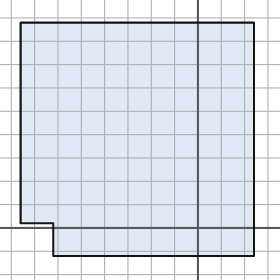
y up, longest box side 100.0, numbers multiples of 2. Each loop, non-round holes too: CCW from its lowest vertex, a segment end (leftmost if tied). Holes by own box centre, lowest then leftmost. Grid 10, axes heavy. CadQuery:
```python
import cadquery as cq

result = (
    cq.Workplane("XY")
    .moveTo(-62.0, -12.0)
    .lineTo(24.0, -12.0)
    .lineTo(24.0, 88.0)
    .lineTo(-76.0, 88.0)
    .lineTo(-76.0, 2.0)
    .lineTo(-62.0, 2.0)
    .close()
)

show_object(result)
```